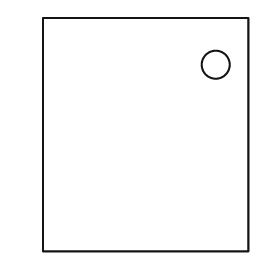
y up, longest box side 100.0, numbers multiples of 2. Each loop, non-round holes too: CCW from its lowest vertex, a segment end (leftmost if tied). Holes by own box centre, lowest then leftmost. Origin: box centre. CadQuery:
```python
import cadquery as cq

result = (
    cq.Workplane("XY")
    .moveTo(-44.0, -50.0)
    .lineTo(44.0, -50.0)
    .lineTo(44.0, 50.0)
    .lineTo(-44.0, 50.0)
    .close()
    .moveTo(30.0, 30.0)
    .circle(6.0)
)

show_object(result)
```